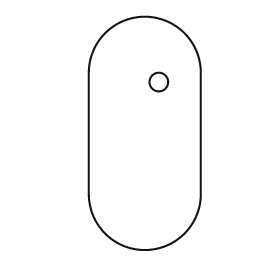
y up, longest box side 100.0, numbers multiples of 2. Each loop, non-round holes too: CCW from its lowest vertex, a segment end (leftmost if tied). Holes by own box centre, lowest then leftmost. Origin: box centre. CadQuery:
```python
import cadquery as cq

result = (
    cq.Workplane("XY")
    .moveTo(-24.0, -26.0)
    .threePointArc((0.0, -50.0), (24.0, -26.0))
    .lineTo(24.0, 26.0)
    .threePointArc((0.0, 50.0), (-24.0, 26.0))
    .close()
    .moveTo(6.0, 22.0)
    .circle(4.0)
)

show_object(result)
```